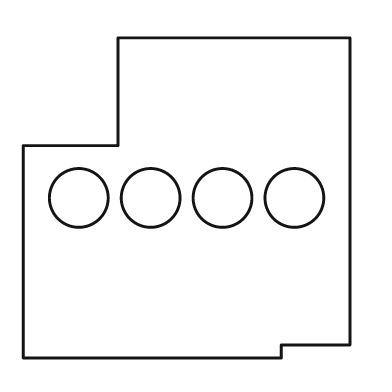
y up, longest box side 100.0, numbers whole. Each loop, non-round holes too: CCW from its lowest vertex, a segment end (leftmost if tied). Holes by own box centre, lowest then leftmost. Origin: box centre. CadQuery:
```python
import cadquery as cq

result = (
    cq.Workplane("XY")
    .moveTo(-50.0, -49.0)
    .lineTo(29.0, -49.0)
    .lineTo(29.0, -45.0)
    .lineTo(50.0, -45.0)
    .lineTo(50.0, 49.0)
    .lineTo(-21.0, 49.0)
    .lineTo(-21.0, 16.0)
    .lineTo(-50.0, 16.0)
    .close()
    .moveTo(-33.0, 0.0)
    .circle(9.0)
    .moveTo(-11.0, 0.0)
    .circle(9.0)
    .moveTo(11.0, 0.0)
    .circle(9.0)
    .moveTo(33.0, 0.0)
    .circle(9.0)
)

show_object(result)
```